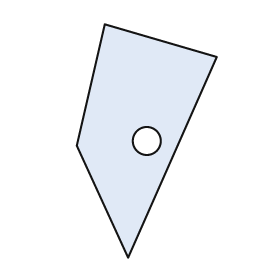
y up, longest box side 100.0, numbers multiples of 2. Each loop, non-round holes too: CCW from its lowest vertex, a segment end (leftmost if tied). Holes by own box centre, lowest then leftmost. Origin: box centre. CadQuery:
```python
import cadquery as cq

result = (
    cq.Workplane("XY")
    .moveTo(-8.0, -50.0)
    .lineTo(30.0, 36.0)
    .lineTo(-18.0, 50.0)
    .lineTo(-30.0, -2.0)
    .close()
    .moveTo(0.0, 0.0)
    .circle(6.0)
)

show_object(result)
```